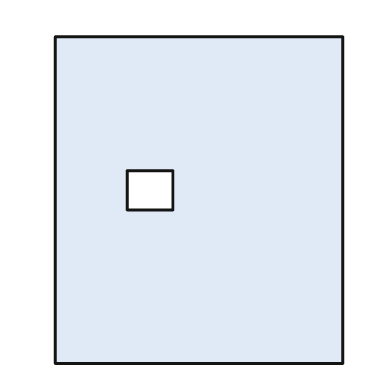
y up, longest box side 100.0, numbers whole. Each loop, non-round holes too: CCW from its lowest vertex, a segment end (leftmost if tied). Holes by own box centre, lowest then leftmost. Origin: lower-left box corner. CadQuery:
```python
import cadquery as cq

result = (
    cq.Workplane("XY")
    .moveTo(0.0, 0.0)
    .lineTo(88.0, 0.0)
    .lineTo(88.0, 100.0)
    .lineTo(0.0, 100.0)
    .close()
    .moveTo(22.0, 47.0)
    .lineTo(36.0, 47.0)
    .lineTo(36.0, 59.0)
    .lineTo(22.0, 59.0)
    .close()
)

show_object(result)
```